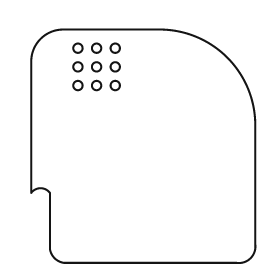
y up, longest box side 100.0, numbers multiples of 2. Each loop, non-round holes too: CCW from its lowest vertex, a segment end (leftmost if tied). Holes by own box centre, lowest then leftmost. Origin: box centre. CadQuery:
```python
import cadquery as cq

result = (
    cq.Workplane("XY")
    .moveTo(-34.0, -50.0)
    .lineTo(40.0, -50.0)
    .threePointArc((46.0, -48.0), (48.0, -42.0))
    .lineTo(48.0, 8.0)
    .threePointArc((36.0, 38.0), (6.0, 50.0))
    .lineTo(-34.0, 50.0)
    .threePointArc((-44.0, 46.0), (-48.0, 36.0))
    .lineTo(-48.0, -20.0)
    .threePointArc((-44.0, -18.0), (-40.0, -20.0))
    .lineTo(-40.0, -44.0)
    .threePointArc((-38.0, -48.0), (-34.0, -50.0))
    .close()
    .moveTo(-28.0, 26.0)
    .circle(2.0)
    .moveTo(-20.0, 26.0)
    .circle(2.0)
    .moveTo(-12.0, 26.0)
    .circle(2.0)
    .moveTo(-28.0, 34.0)
    .circle(2.0)
    .moveTo(-20.0, 34.0)
    .circle(2.0)
    .moveTo(-12.0, 34.0)
    .circle(2.0)
    .moveTo(-28.0, 42.0)
    .circle(2.0)
    .moveTo(-20.0, 42.0)
    .circle(2.0)
    .moveTo(-12.0, 42.0)
    .circle(2.0)
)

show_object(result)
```